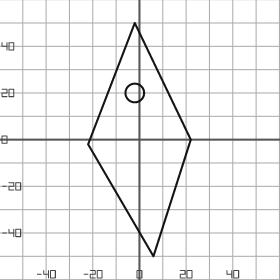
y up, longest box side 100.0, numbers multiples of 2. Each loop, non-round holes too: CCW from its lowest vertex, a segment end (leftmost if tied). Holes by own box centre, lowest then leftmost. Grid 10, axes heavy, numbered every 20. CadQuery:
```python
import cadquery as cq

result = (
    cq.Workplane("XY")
    .moveTo(6.0, -50.0)
    .lineTo(22.0, 0.0)
    .lineTo(-2.0, 50.0)
    .lineTo(-22.0, -2.0)
    .close()
    .moveTo(-2.0, 20.0)
    .circle(4.0)
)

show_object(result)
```